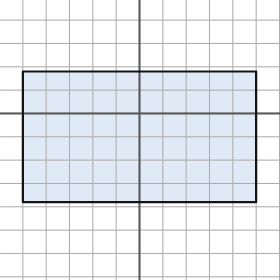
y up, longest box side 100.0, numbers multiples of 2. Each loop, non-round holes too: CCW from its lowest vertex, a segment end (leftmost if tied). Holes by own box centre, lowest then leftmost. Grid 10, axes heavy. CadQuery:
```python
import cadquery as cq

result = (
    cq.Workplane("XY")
    .moveTo(-50.0, -38.0)
    .lineTo(50.0, -38.0)
    .lineTo(50.0, 18.0)
    .lineTo(-50.0, 18.0)
    .close()
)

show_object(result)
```